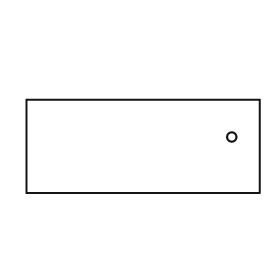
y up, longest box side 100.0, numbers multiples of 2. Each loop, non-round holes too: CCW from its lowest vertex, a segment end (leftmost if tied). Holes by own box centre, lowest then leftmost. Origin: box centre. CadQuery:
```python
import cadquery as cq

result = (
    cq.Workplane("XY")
    .moveTo(-50.0, -20.0)
    .lineTo(50.0, -20.0)
    .lineTo(50.0, 20.0)
    .lineTo(-50.0, 20.0)
    .close()
    .moveTo(38.0, 4.0)
    .circle(2.0)
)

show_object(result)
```